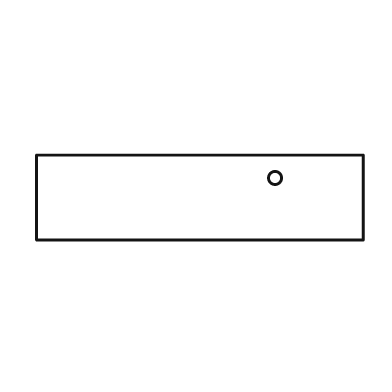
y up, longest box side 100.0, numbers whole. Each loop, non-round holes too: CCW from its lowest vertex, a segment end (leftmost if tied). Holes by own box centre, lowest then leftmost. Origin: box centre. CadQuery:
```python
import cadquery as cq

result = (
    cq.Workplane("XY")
    .moveTo(-50.0, -13.0)
    .lineTo(50.0, -13.0)
    .lineTo(50.0, 13.0)
    .lineTo(-50.0, 13.0)
    .close()
    .moveTo(23.0, 6.0)
    .circle(2.0)
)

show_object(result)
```